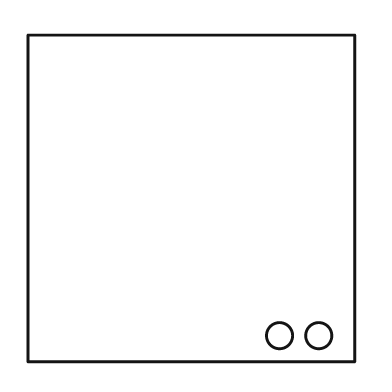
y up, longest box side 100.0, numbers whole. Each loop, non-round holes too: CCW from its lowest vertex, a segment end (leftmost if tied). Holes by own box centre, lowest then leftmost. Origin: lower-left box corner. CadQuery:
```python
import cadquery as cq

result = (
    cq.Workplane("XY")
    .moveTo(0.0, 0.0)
    .lineTo(100.0, 0.0)
    .lineTo(100.0, 100.0)
    .lineTo(0.0, 100.0)
    .close()
    .moveTo(77.0, 8.0)
    .circle(4.0)
    .moveTo(89.0, 8.0)
    .circle(4.0)
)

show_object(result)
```